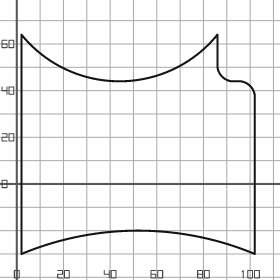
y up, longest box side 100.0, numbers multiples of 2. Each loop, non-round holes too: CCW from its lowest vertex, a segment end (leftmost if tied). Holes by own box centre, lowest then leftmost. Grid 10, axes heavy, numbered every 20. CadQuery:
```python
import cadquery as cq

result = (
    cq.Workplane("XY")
    .moveTo(2.0, -30.0)
    .threePointArc((52.0, -20.0), (102.0, -30.0))
    .lineTo(102.0, 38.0)
    .threePointArc((100.0, 42.0), (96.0, 44.0))
    .lineTo(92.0, 44.0)
    .threePointArc((88.0, 46.0), (86.0, 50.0))
    .lineTo(86.0, 64.0)
    .threePointArc((44.0, 44.0), (2.0, 64.0))
    .close()
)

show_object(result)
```